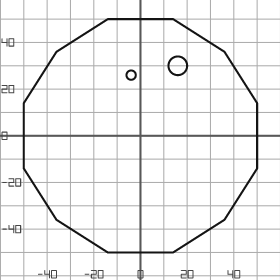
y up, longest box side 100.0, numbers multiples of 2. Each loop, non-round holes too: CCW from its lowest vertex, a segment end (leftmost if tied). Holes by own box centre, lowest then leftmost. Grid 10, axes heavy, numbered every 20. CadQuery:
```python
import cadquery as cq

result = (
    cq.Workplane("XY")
    .moveTo(-14.0, -50.0)
    .lineTo(14.0, -50.0)
    .lineTo(36.0, -36.0)
    .lineTo(50.0, -14.0)
    .lineTo(50.0, 14.0)
    .lineTo(36.0, 36.0)
    .lineTo(14.0, 50.0)
    .lineTo(-14.0, 50.0)
    .lineTo(-36.0, 36.0)
    .lineTo(-50.0, 14.0)
    .lineTo(-50.0, -14.0)
    .lineTo(-36.0, -36.0)
    .close()
    .moveTo(-4.0, 26.0)
    .circle(2.0)
    .moveTo(16.0, 30.0)
    .circle(4.0)
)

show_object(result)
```